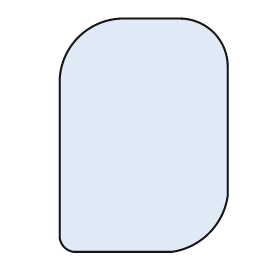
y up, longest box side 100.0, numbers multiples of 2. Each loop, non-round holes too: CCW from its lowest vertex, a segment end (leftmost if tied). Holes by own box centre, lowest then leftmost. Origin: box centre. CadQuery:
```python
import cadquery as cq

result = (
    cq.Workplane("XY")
    .moveTo(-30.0, -50.0)
    .lineTo(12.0, -50.0)
    .threePointArc((28.0, -42.0), (36.0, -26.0))
    .lineTo(36.0, 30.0)
    .threePointArc((30.0, 44.0), (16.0, 50.0))
    .lineTo(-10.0, 50.0)
    .threePointArc((-28.0, 42.0), (-36.0, 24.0))
    .lineTo(-36.0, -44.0)
    .threePointArc((-34.0, -48.0), (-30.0, -50.0))
    .close()
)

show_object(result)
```